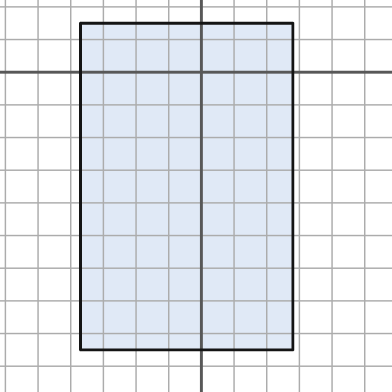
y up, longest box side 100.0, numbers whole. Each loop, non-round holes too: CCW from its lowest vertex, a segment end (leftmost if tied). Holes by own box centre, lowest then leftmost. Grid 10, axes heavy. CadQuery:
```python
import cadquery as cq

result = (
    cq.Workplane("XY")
    .moveTo(-37.0, -85.0)
    .lineTo(28.0, -85.0)
    .lineTo(28.0, 15.0)
    .lineTo(-37.0, 15.0)
    .close()
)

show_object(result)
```